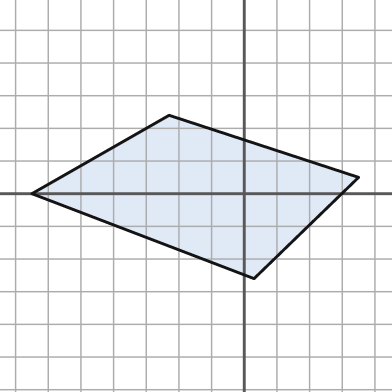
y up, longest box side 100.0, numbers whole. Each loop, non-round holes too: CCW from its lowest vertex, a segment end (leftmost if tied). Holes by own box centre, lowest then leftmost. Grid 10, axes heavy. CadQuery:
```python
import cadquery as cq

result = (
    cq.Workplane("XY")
    .moveTo(3.0, -26.0)
    .lineTo(35.0, 5.0)
    .lineTo(-23.0, 24.0)
    .lineTo(-65.0, 0.0)
    .close()
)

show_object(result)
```